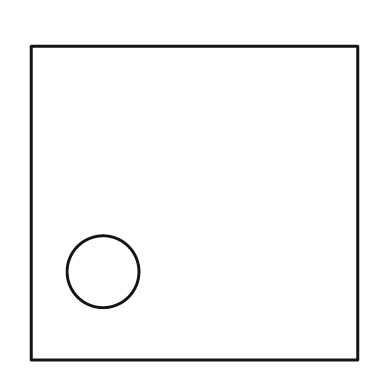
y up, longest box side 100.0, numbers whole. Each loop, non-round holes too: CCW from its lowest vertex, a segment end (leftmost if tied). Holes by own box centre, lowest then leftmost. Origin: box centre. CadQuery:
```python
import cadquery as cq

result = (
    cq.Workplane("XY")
    .moveTo(-50.0, -48.0)
    .lineTo(50.0, -48.0)
    .lineTo(50.0, 48.0)
    .lineTo(-50.0, 48.0)
    .close()
    .moveTo(-28.0, -21.0)
    .circle(11.0)
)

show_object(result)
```